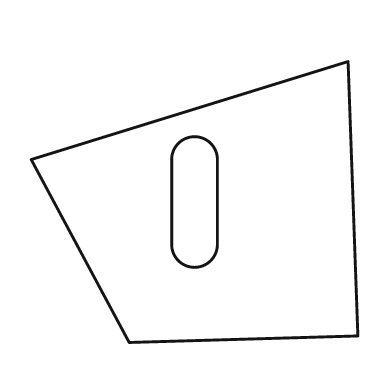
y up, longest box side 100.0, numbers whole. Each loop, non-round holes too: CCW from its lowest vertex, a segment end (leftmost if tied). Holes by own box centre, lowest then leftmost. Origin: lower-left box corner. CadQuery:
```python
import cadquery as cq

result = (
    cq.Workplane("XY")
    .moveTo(30.0, 0.0)
    .lineTo(100.0, 2.0)
    .lineTo(97.0, 86.0)
    .lineTo(0.0, 56.0)
    .close()
    .moveTo(43.0, 30.0)
    .threePointArc((50.0, 23.0), (57.0, 30.0))
    .lineTo(57.0, 56.0)
    .threePointArc((50.0, 63.0), (43.0, 56.0))
    .close()
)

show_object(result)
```